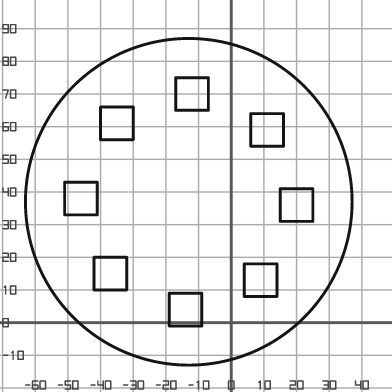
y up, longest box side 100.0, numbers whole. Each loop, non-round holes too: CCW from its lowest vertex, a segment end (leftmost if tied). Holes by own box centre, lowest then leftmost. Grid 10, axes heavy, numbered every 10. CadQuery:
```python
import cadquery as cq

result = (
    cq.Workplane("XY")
    .moveTo(-13.0, 37.0)
    .circle(50.0)
    .moveTo(-19.0, -1.0)
    .lineTo(-9.0, -1.0)
    .lineTo(-9.0, 9.0)
    .lineTo(-19.0, 9.0)
    .close()
    .moveTo(4.0, 8.0)
    .lineTo(14.0, 8.0)
    .lineTo(14.0, 18.0)
    .lineTo(4.0, 18.0)
    .close()
    .moveTo(-42.0, 10.0)
    .lineTo(-32.0, 10.0)
    .lineTo(-32.0, 20.0)
    .lineTo(-42.0, 20.0)
    .close()
    .moveTo(15.0, 31.0)
    .lineTo(25.0, 31.0)
    .lineTo(25.0, 41.0)
    .lineTo(15.0, 41.0)
    .close()
    .moveTo(-51.0, 33.0)
    .lineTo(-41.0, 33.0)
    .lineTo(-41.0, 43.0)
    .lineTo(-51.0, 43.0)
    .close()
    .moveTo(6.0, 54.0)
    .lineTo(16.0, 54.0)
    .lineTo(16.0, 64.0)
    .lineTo(6.0, 64.0)
    .close()
    .moveTo(-40.0, 56.0)
    .lineTo(-30.0, 56.0)
    .lineTo(-30.0, 66.0)
    .lineTo(-40.0, 66.0)
    .close()
    .moveTo(-17.0, 65.0)
    .lineTo(-7.0, 65.0)
    .lineTo(-7.0, 75.0)
    .lineTo(-17.0, 75.0)
    .close()
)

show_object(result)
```